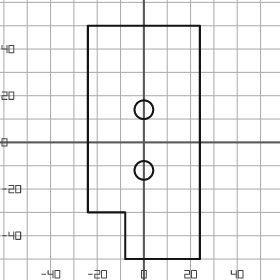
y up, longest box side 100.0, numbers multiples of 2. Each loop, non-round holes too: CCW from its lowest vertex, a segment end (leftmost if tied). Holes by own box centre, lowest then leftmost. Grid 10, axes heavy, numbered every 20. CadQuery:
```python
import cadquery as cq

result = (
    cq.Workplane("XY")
    .moveTo(-8.0, -50.0)
    .lineTo(24.0, -50.0)
    .lineTo(24.0, 50.0)
    .lineTo(-24.0, 50.0)
    .lineTo(-24.0, -30.0)
    .lineTo(-8.0, -30.0)
    .close()
    .moveTo(0.0, -12.0)
    .circle(4.0)
    .moveTo(0.0, 14.0)
    .circle(4.0)
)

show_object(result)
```